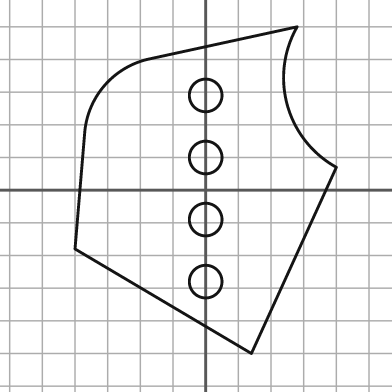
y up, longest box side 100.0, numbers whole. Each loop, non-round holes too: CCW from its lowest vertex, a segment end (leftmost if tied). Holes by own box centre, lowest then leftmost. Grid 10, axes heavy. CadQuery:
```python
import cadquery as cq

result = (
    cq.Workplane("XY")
    .moveTo(14.0, -50.0)
    .lineTo(40.0, 7.0)
    .threePointArc((25.0, 26.0), (28.0, 50.0))
    .lineTo(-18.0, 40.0)
    .threePointArc((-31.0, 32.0), (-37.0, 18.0))
    .lineTo(-40.0, -18.0)
    .close()
    .moveTo(0.0, -28.0)
    .circle(5.0)
    .moveTo(0.0, -9.0)
    .circle(5.0)
    .moveTo(0.0, 10.0)
    .circle(5.0)
    .moveTo(0.0, 29.0)
    .circle(5.0)
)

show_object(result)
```